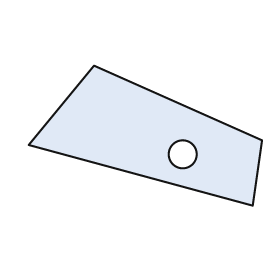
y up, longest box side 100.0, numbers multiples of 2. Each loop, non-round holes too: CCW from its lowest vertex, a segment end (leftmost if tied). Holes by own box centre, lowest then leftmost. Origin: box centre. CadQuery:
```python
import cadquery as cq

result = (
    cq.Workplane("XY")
    .moveTo(46.0, -30.0)
    .lineTo(50.0, -2.0)
    .lineTo(-22.0, 30.0)
    .lineTo(-50.0, -4.0)
    .close()
    .moveTo(16.0, -8.0)
    .circle(6.0)
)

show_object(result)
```